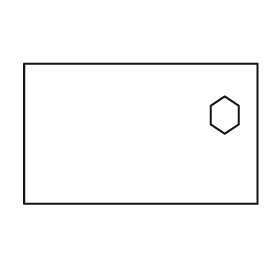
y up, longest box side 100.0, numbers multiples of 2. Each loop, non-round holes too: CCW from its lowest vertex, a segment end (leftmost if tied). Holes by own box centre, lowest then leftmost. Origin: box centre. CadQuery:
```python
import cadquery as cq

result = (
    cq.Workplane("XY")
    .moveTo(-50.0, -30.0)
    .lineTo(50.0, -30.0)
    .lineTo(50.0, 30.0)
    .lineTo(-50.0, 30.0)
    .close()
    .moveTo(36.0, 0.0)
    .lineTo(42.0, 4.0)
    .lineTo(42.0, 12.0)
    .lineTo(36.0, 16.0)
    .lineTo(30.0, 12.0)
    .lineTo(30.0, 4.0)
    .close()
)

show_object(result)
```